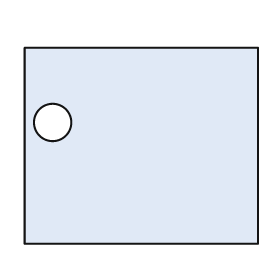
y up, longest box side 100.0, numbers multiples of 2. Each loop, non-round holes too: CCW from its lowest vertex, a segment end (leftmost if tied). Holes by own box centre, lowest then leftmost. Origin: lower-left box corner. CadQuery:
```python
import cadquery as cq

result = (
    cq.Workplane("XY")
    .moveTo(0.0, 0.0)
    .lineTo(100.0, 0.0)
    .lineTo(100.0, 84.0)
    .lineTo(0.0, 84.0)
    .close()
    .moveTo(12.0, 52.0)
    .circle(8.0)
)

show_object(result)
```